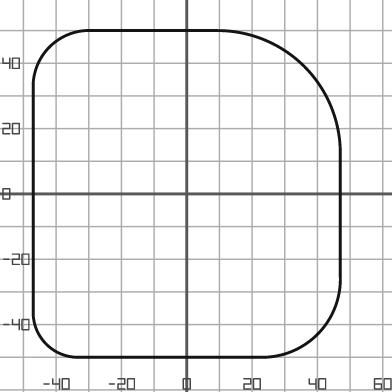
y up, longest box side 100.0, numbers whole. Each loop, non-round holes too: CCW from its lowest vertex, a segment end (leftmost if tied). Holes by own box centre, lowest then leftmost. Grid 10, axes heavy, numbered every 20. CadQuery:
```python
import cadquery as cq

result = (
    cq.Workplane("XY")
    .moveTo(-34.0, -50.0)
    .lineTo(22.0, -50.0)
    .threePointArc((40.0, -43.0), (47.0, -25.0))
    .lineTo(47.0, 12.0)
    .threePointArc((36.0, 39.0), (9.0, 50.0))
    .lineTo(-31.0, 50.0)
    .threePointArc((-42.0, 45.0), (-47.0, 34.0))
    .lineTo(-47.0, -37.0)
    .threePointArc((-43.0, -46.0), (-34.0, -50.0))
    .close()
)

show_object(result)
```